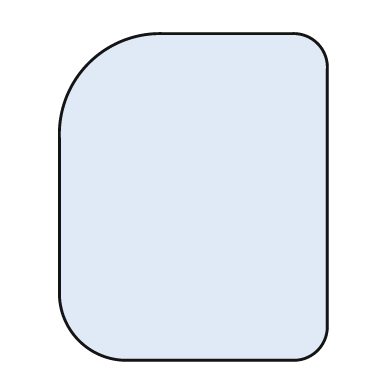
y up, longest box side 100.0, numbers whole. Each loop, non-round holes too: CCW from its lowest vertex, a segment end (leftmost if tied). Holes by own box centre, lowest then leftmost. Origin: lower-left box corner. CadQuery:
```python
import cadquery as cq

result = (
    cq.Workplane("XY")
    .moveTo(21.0, 0.0)
    .lineTo(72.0, 0.0)
    .threePointArc((79.0, 3.0), (82.0, 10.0))
    .lineTo(82.0, 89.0)
    .threePointArc((79.0, 97.0), (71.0, 100.0))
    .lineTo(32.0, 100.0)
    .threePointArc((9.0, 91.0), (0.0, 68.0))
    .lineTo(0.0, 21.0)
    .threePointArc((6.0, 6.0), (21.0, 0.0))
    .close()
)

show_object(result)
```